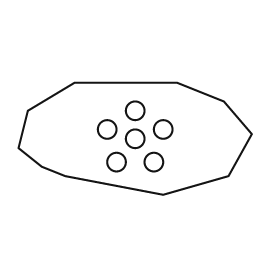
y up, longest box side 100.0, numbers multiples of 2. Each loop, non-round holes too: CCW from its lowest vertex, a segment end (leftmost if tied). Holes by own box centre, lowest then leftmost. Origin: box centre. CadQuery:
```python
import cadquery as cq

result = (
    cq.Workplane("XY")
    .moveTo(12.0, -24.0)
    .lineTo(40.0, -16.0)
    .lineTo(50.0, 2.0)
    .lineTo(38.0, 16.0)
    .lineTo(18.0, 24.0)
    .lineTo(-26.0, 24.0)
    .lineTo(-46.0, 12.0)
    .lineTo(-50.0, -4.0)
    .lineTo(-40.0, -12.0)
    .lineTo(-30.0, -16.0)
    .close()
    .moveTo(-8.0, -10.0)
    .circle(4.0)
    .moveTo(8.0, -10.0)
    .circle(4.0)
    .moveTo(0.0, 0.0)
    .circle(4.0)
    .moveTo(-12.0, 4.0)
    .circle(4.0)
    .moveTo(12.0, 4.0)
    .circle(4.0)
    .moveTo(0.0, 12.0)
    .circle(4.0)
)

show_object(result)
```